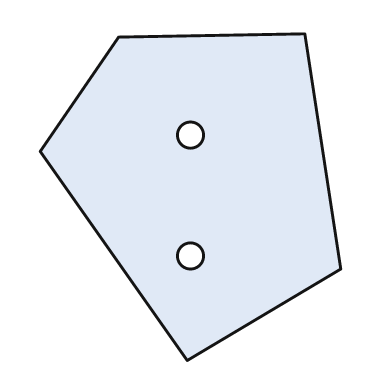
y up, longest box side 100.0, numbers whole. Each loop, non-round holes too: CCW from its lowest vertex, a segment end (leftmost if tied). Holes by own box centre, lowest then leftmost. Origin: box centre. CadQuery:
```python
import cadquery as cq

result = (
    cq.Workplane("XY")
    .moveTo(-1.0, -50.0)
    .lineTo(46.0, -22.0)
    .lineTo(35.0, 50.0)
    .lineTo(-22.0, 49.0)
    .lineTo(-46.0, 14.0)
    .close()
    .moveTo(0.0, -18.0)
    .circle(4.0)
    .moveTo(0.0, 19.0)
    .circle(4.0)
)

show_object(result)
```